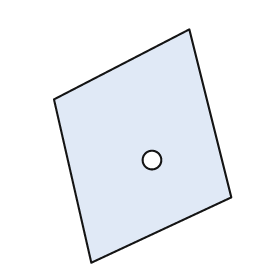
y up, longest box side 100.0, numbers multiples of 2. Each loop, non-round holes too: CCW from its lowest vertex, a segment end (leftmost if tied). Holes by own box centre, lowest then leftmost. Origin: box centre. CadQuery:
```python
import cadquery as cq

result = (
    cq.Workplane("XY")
    .moveTo(-22.0, -50.0)
    .lineTo(38.0, -22.0)
    .lineTo(20.0, 50.0)
    .lineTo(-38.0, 20.0)
    .close()
    .moveTo(4.0, -6.0)
    .circle(4.0)
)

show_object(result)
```